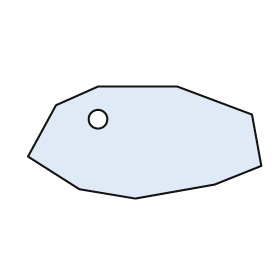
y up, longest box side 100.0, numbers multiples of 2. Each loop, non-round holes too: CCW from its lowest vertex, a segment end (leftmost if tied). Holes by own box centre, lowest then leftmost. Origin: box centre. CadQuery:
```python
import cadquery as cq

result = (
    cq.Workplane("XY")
    .moveTo(-4.0, -24.0)
    .lineTo(30.0, -18.0)
    .lineTo(50.0, -10.0)
    .lineTo(46.0, 12.0)
    .lineTo(14.0, 24.0)
    .lineTo(-20.0, 24.0)
    .lineTo(-38.0, 16.0)
    .lineTo(-50.0, -6.0)
    .lineTo(-28.0, -20.0)
    .close()
    .moveTo(-20.0, 10.0)
    .circle(4.0)
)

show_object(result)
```